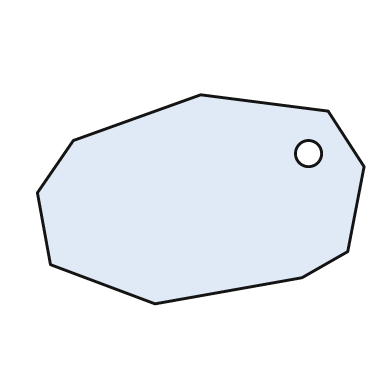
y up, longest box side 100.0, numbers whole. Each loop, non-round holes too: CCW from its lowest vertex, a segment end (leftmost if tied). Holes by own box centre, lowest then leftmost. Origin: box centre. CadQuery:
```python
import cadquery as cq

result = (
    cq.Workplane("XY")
    .moveTo(-14.0, -32.0)
    .lineTo(31.0, -24.0)
    .lineTo(45.0, -16.0)
    .lineTo(50.0, 10.0)
    .lineTo(39.0, 27.0)
    .lineTo(0.0, 32.0)
    .lineTo(-39.0, 18.0)
    .lineTo(-50.0, 2.0)
    .lineTo(-46.0, -20.0)
    .close()
    .moveTo(33.0, 14.0)
    .circle(4.0)
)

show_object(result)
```